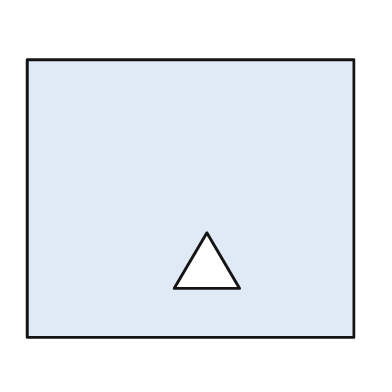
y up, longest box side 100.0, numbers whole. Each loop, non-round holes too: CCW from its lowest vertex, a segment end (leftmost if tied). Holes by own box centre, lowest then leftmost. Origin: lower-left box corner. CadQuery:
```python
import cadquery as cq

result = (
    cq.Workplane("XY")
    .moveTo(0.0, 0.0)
    .lineTo(100.0, 0.0)
    .lineTo(100.0, 85.0)
    .lineTo(0.0, 85.0)
    .close()
    .moveTo(45.0, 15.0)
    .lineTo(65.0, 15.0)
    .lineTo(55.0, 32.0)
    .close()
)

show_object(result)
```